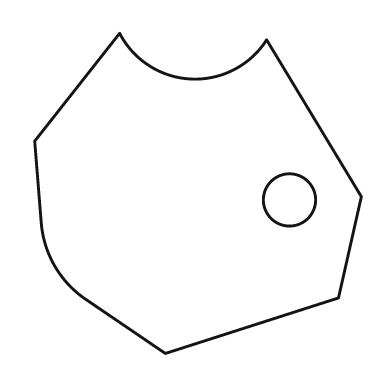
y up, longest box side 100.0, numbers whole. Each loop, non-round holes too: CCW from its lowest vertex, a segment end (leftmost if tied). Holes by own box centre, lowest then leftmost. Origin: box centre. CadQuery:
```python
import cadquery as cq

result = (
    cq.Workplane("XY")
    .moveTo(-10.0, -49.0)
    .lineTo(43.0, -32.0)
    .lineTo(50.0, -1.0)
    .lineTo(21.0, 47.0)
    .threePointArc((-2.0, 35.0), (-24.0, 49.0))
    .lineTo(-50.0, 16.0)
    .lineTo(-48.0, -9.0)
    .threePointArc((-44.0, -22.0), (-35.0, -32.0))
    .close()
    .moveTo(28.0, -2.0)
    .circle(8.0)
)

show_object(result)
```